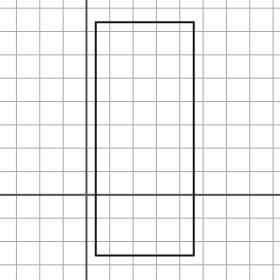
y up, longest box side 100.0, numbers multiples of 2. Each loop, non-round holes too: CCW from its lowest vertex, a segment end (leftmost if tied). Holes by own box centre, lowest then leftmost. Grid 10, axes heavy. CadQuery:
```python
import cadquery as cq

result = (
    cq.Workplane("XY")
    .moveTo(4.0, -26.0)
    .lineTo(46.0, -26.0)
    .lineTo(46.0, 74.0)
    .lineTo(4.0, 74.0)
    .close()
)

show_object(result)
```